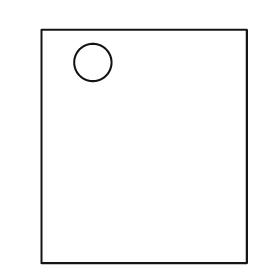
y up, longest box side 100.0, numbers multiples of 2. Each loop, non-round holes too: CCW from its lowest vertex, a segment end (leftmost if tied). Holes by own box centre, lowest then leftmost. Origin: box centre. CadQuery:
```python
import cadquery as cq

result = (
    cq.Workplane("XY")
    .moveTo(-44.0, -50.0)
    .lineTo(44.0, -50.0)
    .lineTo(44.0, 50.0)
    .lineTo(-44.0, 50.0)
    .close()
    .moveTo(-22.0, 36.0)
    .circle(8.0)
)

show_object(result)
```